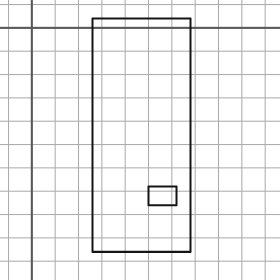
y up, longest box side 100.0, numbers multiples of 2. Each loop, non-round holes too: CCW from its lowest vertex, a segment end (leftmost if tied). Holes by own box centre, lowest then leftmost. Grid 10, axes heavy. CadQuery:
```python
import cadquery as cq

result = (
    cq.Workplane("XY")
    .moveTo(26.0, -96.0)
    .lineTo(68.0, -96.0)
    .lineTo(68.0, 4.0)
    .lineTo(26.0, 4.0)
    .close()
    .moveTo(50.0, -76.0)
    .lineTo(62.0, -76.0)
    .lineTo(62.0, -68.0)
    .lineTo(50.0, -68.0)
    .close()
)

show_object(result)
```